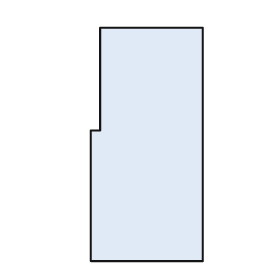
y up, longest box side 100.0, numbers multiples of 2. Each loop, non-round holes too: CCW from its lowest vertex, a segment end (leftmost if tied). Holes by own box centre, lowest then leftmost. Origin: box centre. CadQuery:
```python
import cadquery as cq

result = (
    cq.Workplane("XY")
    .moveTo(-24.0, -50.0)
    .lineTo(24.0, -50.0)
    .lineTo(24.0, 50.0)
    .lineTo(-20.0, 50.0)
    .lineTo(-20.0, 6.0)
    .lineTo(-24.0, 6.0)
    .close()
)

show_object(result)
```